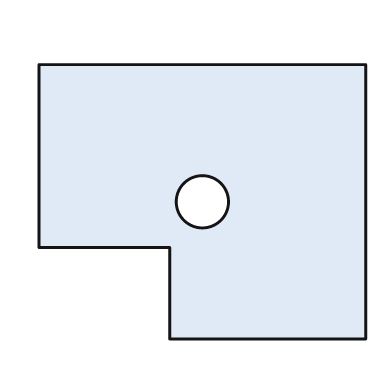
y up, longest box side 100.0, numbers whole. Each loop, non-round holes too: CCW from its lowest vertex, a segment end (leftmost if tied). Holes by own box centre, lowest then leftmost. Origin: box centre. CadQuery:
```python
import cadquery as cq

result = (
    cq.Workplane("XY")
    .moveTo(-10.0, -42.0)
    .lineTo(50.0, -42.0)
    .lineTo(50.0, 42.0)
    .lineTo(-50.0, 42.0)
    .lineTo(-50.0, -14.0)
    .lineTo(-10.0, -14.0)
    .close()
    .moveTo(0.0, 0.0)
    .circle(8.0)
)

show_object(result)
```